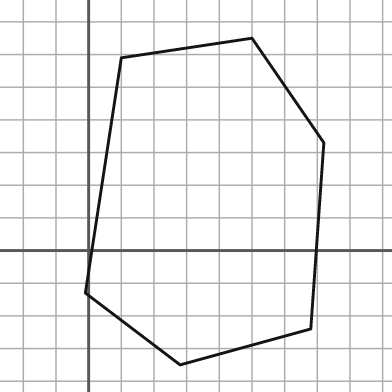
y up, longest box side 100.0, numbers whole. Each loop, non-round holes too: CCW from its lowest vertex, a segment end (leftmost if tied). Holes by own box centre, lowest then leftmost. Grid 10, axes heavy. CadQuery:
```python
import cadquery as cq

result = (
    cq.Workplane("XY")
    .moveTo(28.0, -35.0)
    .lineTo(68.0, -24.0)
    .lineTo(72.0, 33.0)
    .lineTo(50.0, 65.0)
    .lineTo(10.0, 59.0)
    .lineTo(-1.0, -13.0)
    .close()
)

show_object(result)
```